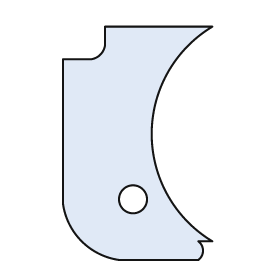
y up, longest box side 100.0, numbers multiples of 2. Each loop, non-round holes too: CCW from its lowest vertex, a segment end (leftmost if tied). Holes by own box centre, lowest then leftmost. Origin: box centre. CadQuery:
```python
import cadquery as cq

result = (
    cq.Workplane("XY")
    .moveTo(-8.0, -50.0)
    .lineTo(26.0, -50.0)
    .threePointArc((28.0, -46.0), (26.0, -42.0))
    .lineTo(32.0, -42.0)
    .threePointArc((6.0, 4.0), (32.0, 50.0))
    .lineTo(-14.0, 50.0)
    .lineTo(-14.0, 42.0)
    .threePointArc((-16.0, 38.0), (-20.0, 36.0))
    .lineTo(-32.0, 36.0)
    .lineTo(-32.0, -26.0)
    .threePointArc((-24.0, -42.0), (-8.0, -50.0))
    .close()
    .moveTo(-2.0, -24.0)
    .circle(6.0)
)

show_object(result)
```